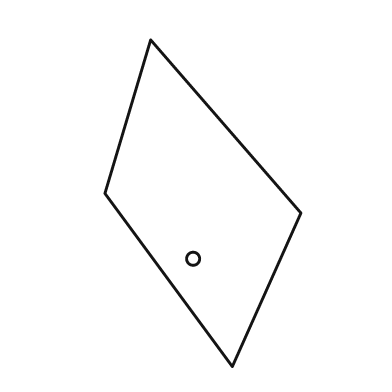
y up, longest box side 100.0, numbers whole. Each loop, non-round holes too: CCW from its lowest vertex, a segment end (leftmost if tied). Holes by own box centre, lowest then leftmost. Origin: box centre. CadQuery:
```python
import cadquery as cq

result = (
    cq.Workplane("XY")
    .moveTo(9.0, -50.0)
    .lineTo(30.0, -3.0)
    .lineTo(-16.0, 50.0)
    .lineTo(-30.0, 3.0)
    .close()
    .moveTo(-3.0, -17.0)
    .circle(2.0)
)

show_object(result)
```